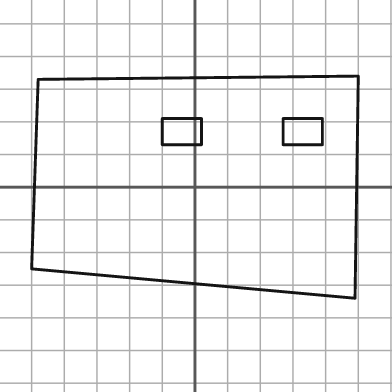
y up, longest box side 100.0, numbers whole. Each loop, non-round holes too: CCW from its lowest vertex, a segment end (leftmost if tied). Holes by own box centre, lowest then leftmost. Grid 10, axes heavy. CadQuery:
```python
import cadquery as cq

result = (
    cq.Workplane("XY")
    .moveTo(49.0, -34.0)
    .lineTo(50.0, 34.0)
    .lineTo(-48.0, 33.0)
    .lineTo(-50.0, -25.0)
    .close()
    .moveTo(-10.0, 13.0)
    .lineTo(2.0, 13.0)
    .lineTo(2.0, 21.0)
    .lineTo(-10.0, 21.0)
    .close()
    .moveTo(27.0, 13.0)
    .lineTo(39.0, 13.0)
    .lineTo(39.0, 21.0)
    .lineTo(27.0, 21.0)
    .close()
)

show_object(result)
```